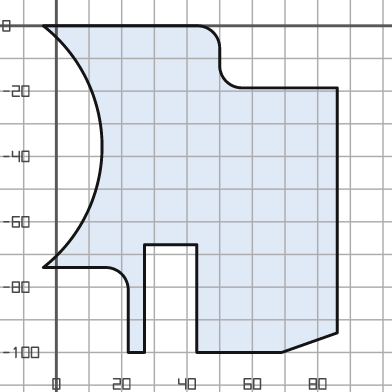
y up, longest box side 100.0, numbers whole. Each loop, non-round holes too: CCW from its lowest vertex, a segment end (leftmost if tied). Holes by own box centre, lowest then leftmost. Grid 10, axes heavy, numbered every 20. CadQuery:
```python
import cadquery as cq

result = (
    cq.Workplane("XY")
    .moveTo(22.0, -100.0)
    .lineTo(27.0, -100.0)
    .lineTo(27.0, -67.0)
    .lineTo(43.0, -67.0)
    .lineTo(43.0, -100.0)
    .lineTo(69.0, -100.0)
    .lineTo(86.0, -94.0)
    .lineTo(86.0, -19.0)
    .lineTo(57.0, -19.0)
    .threePointArc((52.0, -17.0), (50.0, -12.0))
    .lineTo(50.0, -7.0)
    .threePointArc((48.0, -2.0), (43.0, 0.0))
    .lineTo(-4.0, 0.0)
    .threePointArc((14.0, -37.0), (-4.0, -74.0))
    .lineTo(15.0, -74.0)
    .threePointArc((20.0, -76.0), (22.0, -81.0))
    .close()
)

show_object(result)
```